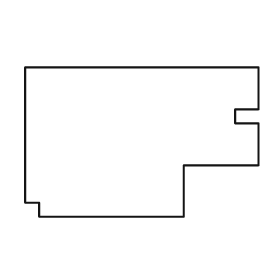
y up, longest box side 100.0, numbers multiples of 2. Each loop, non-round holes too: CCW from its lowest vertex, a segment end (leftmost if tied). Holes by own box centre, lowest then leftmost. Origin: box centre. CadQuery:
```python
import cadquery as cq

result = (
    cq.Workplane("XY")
    .moveTo(-44.0, -32.0)
    .lineTo(18.0, -32.0)
    .lineTo(18.0, -10.0)
    .lineTo(50.0, -10.0)
    .lineTo(50.0, 8.0)
    .lineTo(40.0, 8.0)
    .lineTo(40.0, 14.0)
    .lineTo(50.0, 14.0)
    .lineTo(50.0, 32.0)
    .lineTo(-50.0, 32.0)
    .lineTo(-50.0, -26.0)
    .lineTo(-44.0, -26.0)
    .close()
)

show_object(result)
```